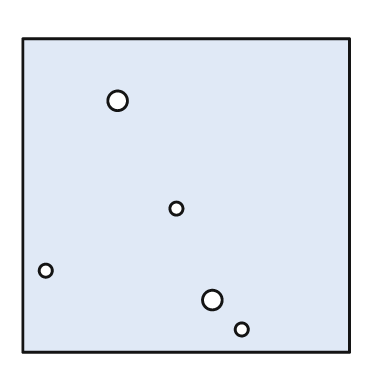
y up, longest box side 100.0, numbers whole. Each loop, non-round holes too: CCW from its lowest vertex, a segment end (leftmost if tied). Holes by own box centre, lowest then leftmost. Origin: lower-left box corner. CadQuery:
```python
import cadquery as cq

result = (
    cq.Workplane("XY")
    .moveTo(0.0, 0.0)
    .lineTo(100.0, 0.0)
    .lineTo(100.0, 96.0)
    .lineTo(0.0, 96.0)
    .close()
    .moveTo(67.0, 7.0)
    .circle(2.0)
    .moveTo(58.0, 16.0)
    .circle(3.0)
    .moveTo(7.0, 25.0)
    .circle(2.0)
    .moveTo(47.0, 44.0)
    .circle(2.0)
    .moveTo(29.0, 77.0)
    .circle(3.0)
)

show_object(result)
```